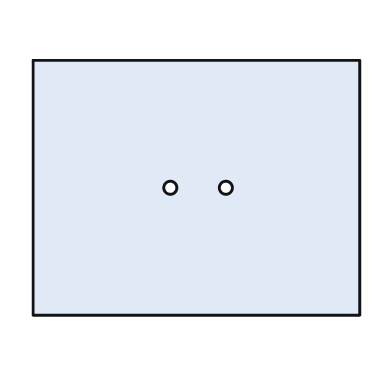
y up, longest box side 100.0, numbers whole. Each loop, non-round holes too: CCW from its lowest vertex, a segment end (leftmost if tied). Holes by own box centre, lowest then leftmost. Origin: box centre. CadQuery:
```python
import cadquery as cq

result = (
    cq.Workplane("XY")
    .moveTo(-50.0, -39.0)
    .lineTo(50.0, -39.0)
    .lineTo(50.0, 39.0)
    .lineTo(-50.0, 39.0)
    .close()
    .moveTo(-8.0, 0.0)
    .circle(2.0)
    .moveTo(9.0, 0.0)
    .circle(2.0)
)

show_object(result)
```